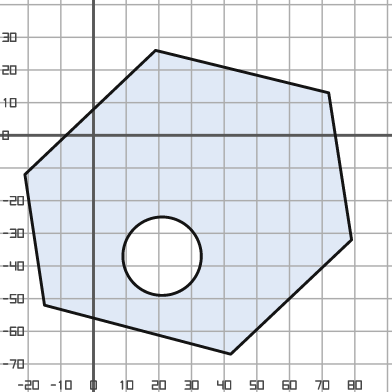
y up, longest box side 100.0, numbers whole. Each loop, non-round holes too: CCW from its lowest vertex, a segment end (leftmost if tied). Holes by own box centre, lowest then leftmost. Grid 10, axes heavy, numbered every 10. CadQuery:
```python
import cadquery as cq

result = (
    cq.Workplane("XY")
    .moveTo(42.0, -67.0)
    .lineTo(79.0, -32.0)
    .lineTo(72.0, 13.0)
    .lineTo(19.0, 26.0)
    .lineTo(-21.0, -12.0)
    .lineTo(-15.0, -52.0)
    .close()
    .moveTo(21.0, -37.0)
    .circle(12.0)
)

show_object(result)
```